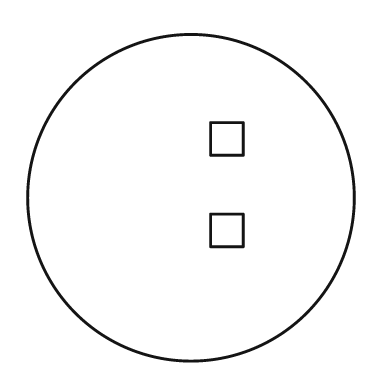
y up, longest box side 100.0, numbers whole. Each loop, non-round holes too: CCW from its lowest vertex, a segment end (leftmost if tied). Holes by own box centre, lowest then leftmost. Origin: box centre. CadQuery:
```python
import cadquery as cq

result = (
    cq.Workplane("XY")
    .moveTo(0.0, 0.0)
    .circle(50.0)
    .moveTo(6.0, -15.0)
    .lineTo(16.0, -15.0)
    .lineTo(16.0, -5.0)
    .lineTo(6.0, -5.0)
    .close()
    .moveTo(6.0, 13.0)
    .lineTo(16.0, 13.0)
    .lineTo(16.0, 23.0)
    .lineTo(6.0, 23.0)
    .close()
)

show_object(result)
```